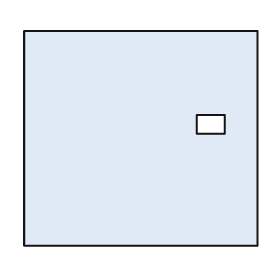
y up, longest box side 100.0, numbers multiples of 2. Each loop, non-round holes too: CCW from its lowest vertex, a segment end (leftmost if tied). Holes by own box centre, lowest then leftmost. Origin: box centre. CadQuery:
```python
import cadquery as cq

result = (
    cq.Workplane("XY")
    .moveTo(-50.0, -46.0)
    .lineTo(50.0, -46.0)
    .lineTo(50.0, 46.0)
    .lineTo(-50.0, 46.0)
    .close()
    .moveTo(24.0, 2.0)
    .lineTo(36.0, 2.0)
    .lineTo(36.0, 10.0)
    .lineTo(24.0, 10.0)
    .close()
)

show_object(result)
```